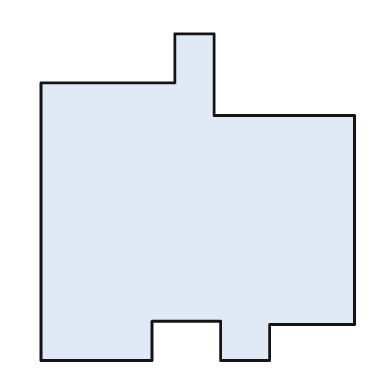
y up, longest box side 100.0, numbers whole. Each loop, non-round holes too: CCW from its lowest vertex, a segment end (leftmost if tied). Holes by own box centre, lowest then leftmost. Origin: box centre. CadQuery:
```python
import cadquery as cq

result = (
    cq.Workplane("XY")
    .moveTo(-48.0, -50.0)
    .lineTo(-14.0, -50.0)
    .lineTo(-14.0, -38.0)
    .lineTo(7.0, -38.0)
    .lineTo(7.0, -50.0)
    .lineTo(22.0, -50.0)
    .lineTo(22.0, -39.0)
    .lineTo(48.0, -39.0)
    .lineTo(48.0, 25.0)
    .lineTo(5.0, 25.0)
    .lineTo(5.0, 50.0)
    .lineTo(-7.0, 50.0)
    .lineTo(-7.0, 35.0)
    .lineTo(-48.0, 35.0)
    .close()
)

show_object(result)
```